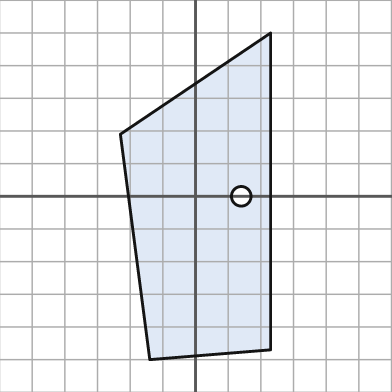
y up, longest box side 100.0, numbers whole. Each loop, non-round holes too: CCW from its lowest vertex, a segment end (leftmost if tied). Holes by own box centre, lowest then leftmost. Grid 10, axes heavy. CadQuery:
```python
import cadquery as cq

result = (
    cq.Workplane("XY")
    .moveTo(-14.0, -50.0)
    .lineTo(23.0, -47.0)
    .lineTo(23.0, 50.0)
    .lineTo(-23.0, 19.0)
    .close()
    .moveTo(14.0, 0.0)
    .circle(3.0)
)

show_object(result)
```